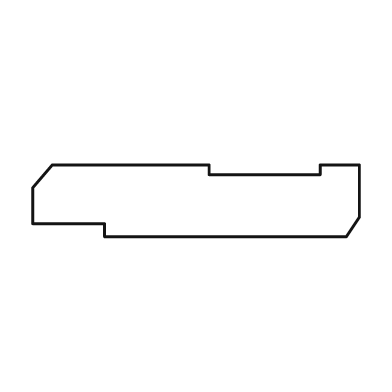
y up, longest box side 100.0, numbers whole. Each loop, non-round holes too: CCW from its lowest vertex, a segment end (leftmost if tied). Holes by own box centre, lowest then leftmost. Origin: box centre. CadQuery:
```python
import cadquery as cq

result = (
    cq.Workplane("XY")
    .moveTo(-28.0, -11.0)
    .lineTo(46.0, -11.0)
    .lineTo(50.0, -5.0)
    .lineTo(50.0, 11.0)
    .lineTo(38.0, 11.0)
    .lineTo(38.0, 8.0)
    .lineTo(4.0, 8.0)
    .lineTo(4.0, 11.0)
    .lineTo(-44.0, 11.0)
    .lineTo(-50.0, 4.0)
    .lineTo(-50.0, -7.0)
    .lineTo(-28.0, -7.0)
    .close()
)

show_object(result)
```